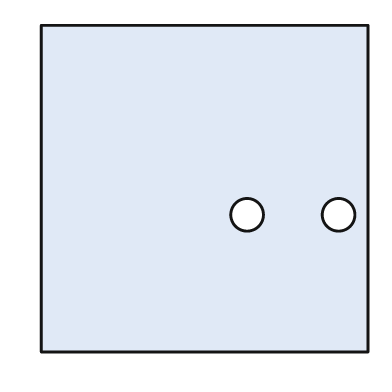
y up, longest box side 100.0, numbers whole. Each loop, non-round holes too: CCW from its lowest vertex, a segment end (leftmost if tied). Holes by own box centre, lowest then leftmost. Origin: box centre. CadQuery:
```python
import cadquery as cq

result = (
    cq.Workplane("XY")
    .moveTo(-50.0, -50.0)
    .lineTo(50.0, -50.0)
    .lineTo(50.0, 50.0)
    .lineTo(-50.0, 50.0)
    .close()
    .moveTo(13.0, -8.0)
    .circle(5.0)
    .moveTo(41.0, -8.0)
    .circle(5.0)
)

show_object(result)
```